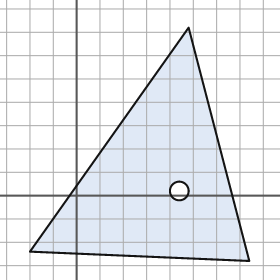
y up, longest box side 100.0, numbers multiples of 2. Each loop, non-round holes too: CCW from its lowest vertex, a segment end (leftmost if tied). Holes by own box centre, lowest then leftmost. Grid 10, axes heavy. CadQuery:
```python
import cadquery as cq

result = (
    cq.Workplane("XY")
    .moveTo(74.0, -28.0)
    .lineTo(48.0, 72.0)
    .lineTo(-20.0, -24.0)
    .close()
    .moveTo(44.0, 2.0)
    .circle(4.0)
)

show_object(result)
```